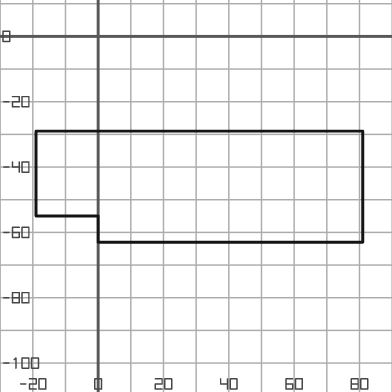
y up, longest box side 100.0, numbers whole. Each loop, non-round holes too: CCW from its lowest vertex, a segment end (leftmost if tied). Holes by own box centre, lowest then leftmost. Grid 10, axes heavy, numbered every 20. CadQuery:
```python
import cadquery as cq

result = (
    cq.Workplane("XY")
    .moveTo(0.0, -63.0)
    .lineTo(81.0, -63.0)
    .lineTo(81.0, -29.0)
    .lineTo(-19.0, -29.0)
    .lineTo(-19.0, -55.0)
    .lineTo(0.0, -55.0)
    .close()
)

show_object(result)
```